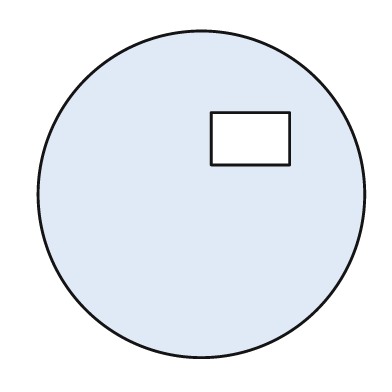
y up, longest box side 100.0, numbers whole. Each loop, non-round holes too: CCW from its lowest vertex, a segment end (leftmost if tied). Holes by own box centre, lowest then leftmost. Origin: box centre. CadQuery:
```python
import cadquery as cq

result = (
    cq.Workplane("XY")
    .moveTo(0.0, 0.0)
    .circle(50.0)
    .moveTo(3.0, 9.0)
    .lineTo(27.0, 9.0)
    .lineTo(27.0, 25.0)
    .lineTo(3.0, 25.0)
    .close()
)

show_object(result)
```